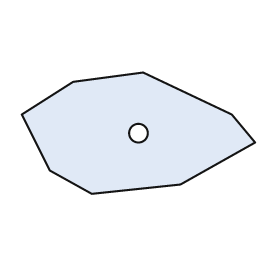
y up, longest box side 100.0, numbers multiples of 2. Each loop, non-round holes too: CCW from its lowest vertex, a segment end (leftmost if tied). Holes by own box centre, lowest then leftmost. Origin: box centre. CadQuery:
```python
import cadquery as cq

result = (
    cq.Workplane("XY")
    .moveTo(-20.0, -26.0)
    .lineTo(18.0, -22.0)
    .lineTo(50.0, -4.0)
    .lineTo(40.0, 8.0)
    .lineTo(2.0, 26.0)
    .lineTo(-28.0, 22.0)
    .lineTo(-50.0, 8.0)
    .lineTo(-38.0, -16.0)
    .close()
    .moveTo(0.0, 0.0)
    .circle(4.0)
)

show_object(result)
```